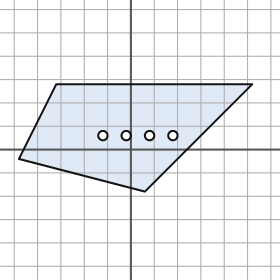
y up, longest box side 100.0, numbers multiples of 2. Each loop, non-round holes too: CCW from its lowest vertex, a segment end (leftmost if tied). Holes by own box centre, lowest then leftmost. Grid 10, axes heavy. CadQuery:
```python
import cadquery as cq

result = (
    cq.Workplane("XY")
    .moveTo(6.0, -18.0)
    .lineTo(52.0, 28.0)
    .lineTo(-32.0, 28.0)
    .lineTo(-48.0, -4.0)
    .close()
    .moveTo(-12.0, 6.0)
    .circle(2.0)
    .moveTo(-2.0, 6.0)
    .circle(2.0)
    .moveTo(8.0, 6.0)
    .circle(2.0)
    .moveTo(18.0, 6.0)
    .circle(2.0)
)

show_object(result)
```